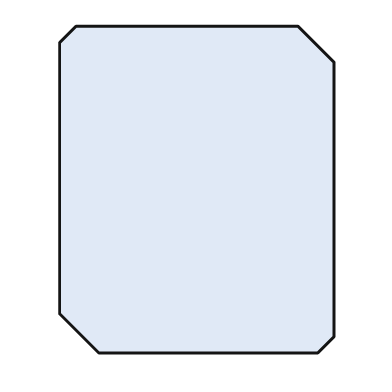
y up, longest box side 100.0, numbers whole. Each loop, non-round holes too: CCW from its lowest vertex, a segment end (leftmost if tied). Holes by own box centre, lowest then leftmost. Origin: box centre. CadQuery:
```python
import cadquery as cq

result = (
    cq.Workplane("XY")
    .moveTo(-30.0, -50.0)
    .lineTo(37.0, -50.0)
    .lineTo(42.0, -45.0)
    .lineTo(42.0, 39.0)
    .lineTo(31.0, 50.0)
    .lineTo(-37.0, 50.0)
    .lineTo(-42.0, 45.0)
    .lineTo(-42.0, -38.0)
    .close()
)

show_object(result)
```